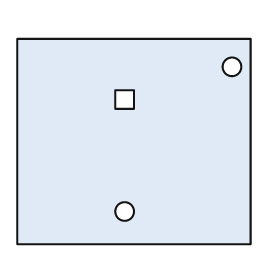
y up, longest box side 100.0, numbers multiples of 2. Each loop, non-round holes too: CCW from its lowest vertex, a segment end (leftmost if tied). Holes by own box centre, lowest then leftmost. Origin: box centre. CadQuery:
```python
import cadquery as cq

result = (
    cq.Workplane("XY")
    .moveTo(-50.0, -44.0)
    .lineTo(50.0, -44.0)
    .lineTo(50.0, 44.0)
    .lineTo(-50.0, 44.0)
    .close()
    .moveTo(-4.0, -30.0)
    .circle(4.0)
    .moveTo(-8.0, 14.0)
    .lineTo(0.0, 14.0)
    .lineTo(0.0, 22.0)
    .lineTo(-8.0, 22.0)
    .close()
    .moveTo(42.0, 32.0)
    .circle(4.0)
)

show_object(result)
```